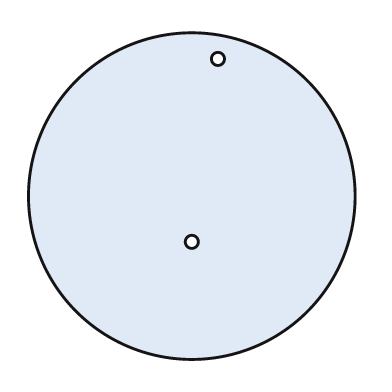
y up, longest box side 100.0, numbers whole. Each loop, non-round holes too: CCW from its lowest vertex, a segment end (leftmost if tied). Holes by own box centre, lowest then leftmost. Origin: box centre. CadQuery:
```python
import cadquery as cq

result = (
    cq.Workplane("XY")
    .moveTo(0.0, 0.0)
    .circle(50.0)
    .moveTo(0.0, -14.0)
    .circle(2.0)
    .moveTo(8.0, 42.0)
    .circle(2.0)
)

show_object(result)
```